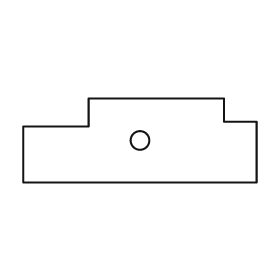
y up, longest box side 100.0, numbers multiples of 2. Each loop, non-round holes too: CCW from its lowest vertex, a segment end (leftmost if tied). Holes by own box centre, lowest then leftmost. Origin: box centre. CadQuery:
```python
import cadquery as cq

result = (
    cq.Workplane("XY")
    .moveTo(-50.0, -18.0)
    .lineTo(50.0, -18.0)
    .lineTo(50.0, 8.0)
    .lineTo(36.0, 8.0)
    .lineTo(36.0, 18.0)
    .lineTo(-22.0, 18.0)
    .lineTo(-22.0, 6.0)
    .lineTo(-50.0, 6.0)
    .close()
    .moveTo(0.0, 0.0)
    .circle(4.0)
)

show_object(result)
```